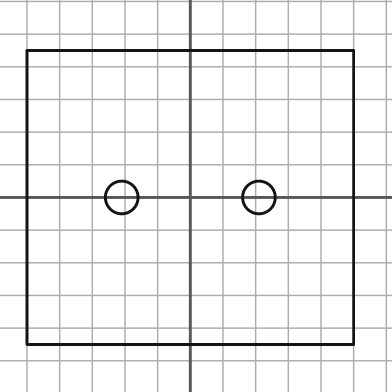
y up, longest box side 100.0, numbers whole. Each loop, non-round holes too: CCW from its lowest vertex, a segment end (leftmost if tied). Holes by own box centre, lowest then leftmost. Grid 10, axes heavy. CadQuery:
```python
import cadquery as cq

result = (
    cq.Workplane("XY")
    .moveTo(-50.0, -45.0)
    .lineTo(50.0, -45.0)
    .lineTo(50.0, 45.0)
    .lineTo(-50.0, 45.0)
    .close()
    .moveTo(-21.0, 0.0)
    .circle(5.0)
    .moveTo(21.0, 0.0)
    .circle(5.0)
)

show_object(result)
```